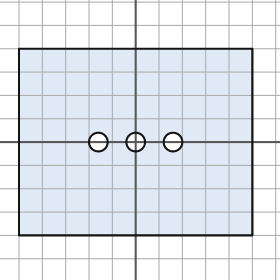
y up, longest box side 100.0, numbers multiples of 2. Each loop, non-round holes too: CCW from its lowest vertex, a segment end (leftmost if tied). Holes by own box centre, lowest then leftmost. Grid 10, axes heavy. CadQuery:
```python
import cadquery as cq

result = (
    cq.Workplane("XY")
    .moveTo(-50.0, -40.0)
    .lineTo(50.0, -40.0)
    .lineTo(50.0, 40.0)
    .lineTo(-50.0, 40.0)
    .close()
    .moveTo(-16.0, 0.0)
    .circle(4.0)
    .moveTo(0.0, 0.0)
    .circle(4.0)
    .moveTo(16.0, 0.0)
    .circle(4.0)
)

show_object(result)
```